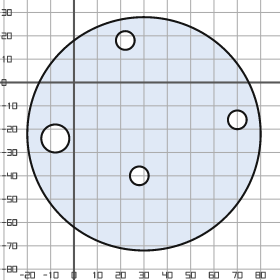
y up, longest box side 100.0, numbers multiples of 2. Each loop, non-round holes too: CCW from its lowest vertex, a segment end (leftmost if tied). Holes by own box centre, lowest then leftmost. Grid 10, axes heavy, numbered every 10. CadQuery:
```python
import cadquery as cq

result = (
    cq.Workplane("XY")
    .moveTo(30.0, -22.0)
    .circle(50.0)
    .moveTo(28.0, -40.0)
    .circle(4.0)
    .moveTo(-8.0, -24.0)
    .circle(6.0)
    .moveTo(70.0, -16.0)
    .circle(4.0)
    .moveTo(22.0, 18.0)
    .circle(4.0)
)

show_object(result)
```